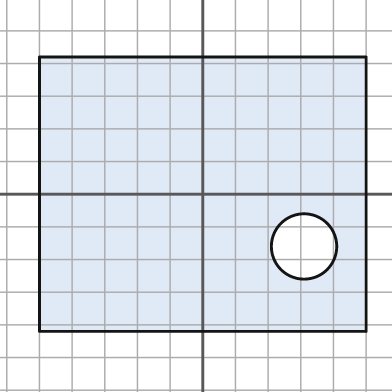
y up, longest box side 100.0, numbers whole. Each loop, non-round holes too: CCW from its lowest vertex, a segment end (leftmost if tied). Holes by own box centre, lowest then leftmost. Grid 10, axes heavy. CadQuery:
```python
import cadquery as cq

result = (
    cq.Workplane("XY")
    .moveTo(-50.0, -42.0)
    .lineTo(50.0, -42.0)
    .lineTo(50.0, 42.0)
    .lineTo(-50.0, 42.0)
    .close()
    .moveTo(31.0, -16.0)
    .circle(10.0)
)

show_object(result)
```